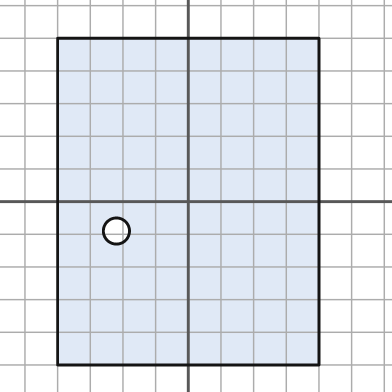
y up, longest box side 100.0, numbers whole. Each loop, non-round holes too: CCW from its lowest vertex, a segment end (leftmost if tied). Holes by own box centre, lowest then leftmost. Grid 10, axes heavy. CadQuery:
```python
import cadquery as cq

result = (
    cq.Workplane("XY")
    .moveTo(-40.0, -50.0)
    .lineTo(40.0, -50.0)
    .lineTo(40.0, 50.0)
    .lineTo(-40.0, 50.0)
    .close()
    .moveTo(-22.0, -9.0)
    .circle(4.0)
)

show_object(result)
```